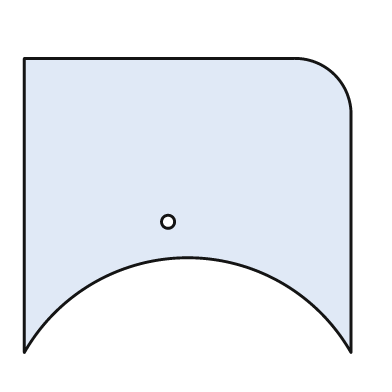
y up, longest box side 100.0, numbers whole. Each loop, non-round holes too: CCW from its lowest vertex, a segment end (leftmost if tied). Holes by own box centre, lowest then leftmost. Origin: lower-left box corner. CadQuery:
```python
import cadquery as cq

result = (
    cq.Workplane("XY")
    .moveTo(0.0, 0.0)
    .threePointArc((50.0, 29.0), (100.0, 0.0))
    .lineTo(100.0, 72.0)
    .threePointArc((95.0, 85.0), (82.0, 90.0))
    .lineTo(0.0, 90.0)
    .close()
    .moveTo(44.0, 40.0)
    .circle(2.0)
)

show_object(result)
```